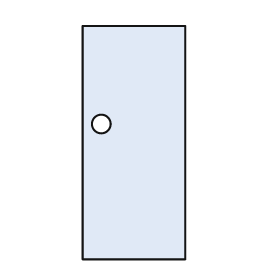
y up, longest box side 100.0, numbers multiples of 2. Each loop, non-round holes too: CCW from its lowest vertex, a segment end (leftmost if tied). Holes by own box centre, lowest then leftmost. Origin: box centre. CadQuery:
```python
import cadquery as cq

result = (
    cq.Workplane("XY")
    .moveTo(-22.0, -50.0)
    .lineTo(22.0, -50.0)
    .lineTo(22.0, 50.0)
    .lineTo(-22.0, 50.0)
    .close()
    .moveTo(-14.0, 8.0)
    .circle(4.0)
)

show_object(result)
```